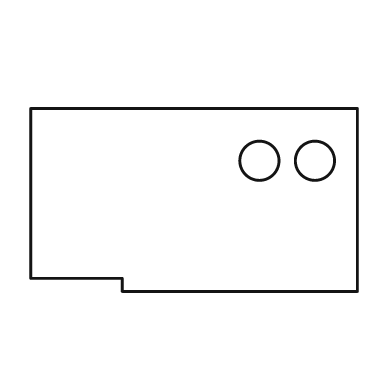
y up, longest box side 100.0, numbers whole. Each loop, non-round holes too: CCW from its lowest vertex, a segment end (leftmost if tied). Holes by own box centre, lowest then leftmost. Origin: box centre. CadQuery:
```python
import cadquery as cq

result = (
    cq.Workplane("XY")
    .moveTo(-22.0, -28.0)
    .lineTo(50.0, -28.0)
    .lineTo(50.0, 28.0)
    .lineTo(-50.0, 28.0)
    .lineTo(-50.0, -24.0)
    .lineTo(-22.0, -24.0)
    .close()
    .moveTo(20.0, 12.0)
    .circle(6.0)
    .moveTo(37.0, 12.0)
    .circle(6.0)
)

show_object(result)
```